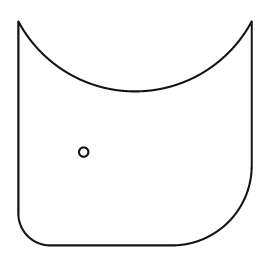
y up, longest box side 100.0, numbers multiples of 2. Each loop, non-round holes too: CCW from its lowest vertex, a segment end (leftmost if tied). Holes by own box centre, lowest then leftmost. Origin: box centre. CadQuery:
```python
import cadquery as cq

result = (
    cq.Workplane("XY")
    .moveTo(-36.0, -48.0)
    .lineTo(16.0, -48.0)
    .threePointArc((40.0, -38.0), (50.0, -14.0))
    .lineTo(50.0, 48.0)
    .threePointArc((0.0, 18.0), (-50.0, 48.0))
    .lineTo(-50.0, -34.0)
    .threePointArc((-46.0, -44.0), (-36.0, -48.0))
    .close()
    .moveTo(-22.0, -8.0)
    .circle(2.0)
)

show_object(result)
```